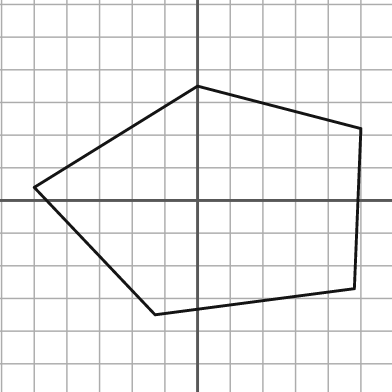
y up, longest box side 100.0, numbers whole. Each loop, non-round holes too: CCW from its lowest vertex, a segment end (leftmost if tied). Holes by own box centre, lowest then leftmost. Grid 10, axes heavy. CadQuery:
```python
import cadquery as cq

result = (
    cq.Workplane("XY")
    .moveTo(-13.0, -35.0)
    .lineTo(48.0, -27.0)
    .lineTo(50.0, 22.0)
    .lineTo(0.0, 35.0)
    .lineTo(-50.0, 4.0)
    .close()
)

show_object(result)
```